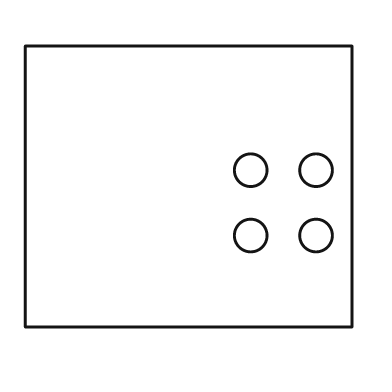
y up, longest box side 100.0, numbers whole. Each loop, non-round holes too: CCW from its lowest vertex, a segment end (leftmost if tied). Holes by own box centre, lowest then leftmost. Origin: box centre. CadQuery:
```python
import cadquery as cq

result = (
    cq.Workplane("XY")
    .moveTo(-50.0, -43.0)
    .lineTo(50.0, -43.0)
    .lineTo(50.0, 43.0)
    .lineTo(-50.0, 43.0)
    .close()
    .moveTo(19.0, -15.0)
    .circle(5.0)
    .moveTo(39.0, -15.0)
    .circle(5.0)
    .moveTo(19.0, 5.0)
    .circle(5.0)
    .moveTo(39.0, 5.0)
    .circle(5.0)
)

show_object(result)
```